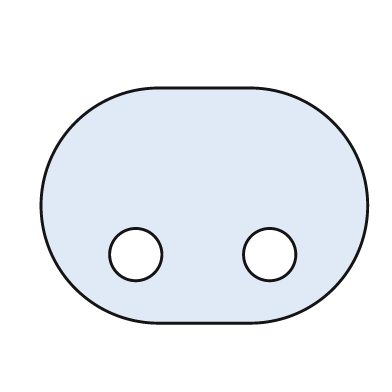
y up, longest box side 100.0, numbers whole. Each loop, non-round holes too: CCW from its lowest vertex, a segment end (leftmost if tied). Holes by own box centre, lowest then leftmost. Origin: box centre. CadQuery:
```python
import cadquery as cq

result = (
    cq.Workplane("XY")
    .moveTo(-14.0, -36.0)
    .lineTo(14.0, -36.0)
    .threePointArc((50.0, 0.0), (14.0, 36.0))
    .lineTo(-14.0, 36.0)
    .threePointArc((-50.0, 0.0), (-14.0, -36.0))
    .close()
    .moveTo(-21.0, -15.0)
    .circle(8.0)
    .moveTo(20.0, -15.0)
    .circle(8.0)
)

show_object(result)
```